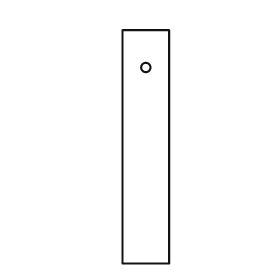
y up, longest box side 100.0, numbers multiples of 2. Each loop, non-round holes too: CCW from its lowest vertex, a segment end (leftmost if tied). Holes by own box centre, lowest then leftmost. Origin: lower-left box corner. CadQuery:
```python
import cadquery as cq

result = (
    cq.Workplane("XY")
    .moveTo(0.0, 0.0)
    .lineTo(20.0, 0.0)
    .lineTo(20.0, 100.0)
    .lineTo(0.0, 100.0)
    .close()
    .moveTo(10.0, 84.0)
    .circle(2.0)
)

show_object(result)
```